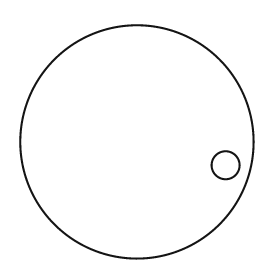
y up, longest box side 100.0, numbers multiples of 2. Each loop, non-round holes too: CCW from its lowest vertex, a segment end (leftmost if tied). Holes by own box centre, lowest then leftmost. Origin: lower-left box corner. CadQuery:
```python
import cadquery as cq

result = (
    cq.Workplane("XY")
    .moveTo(50.0, 50.0)
    .circle(50.0)
    .moveTo(88.0, 40.0)
    .circle(6.0)
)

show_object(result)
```